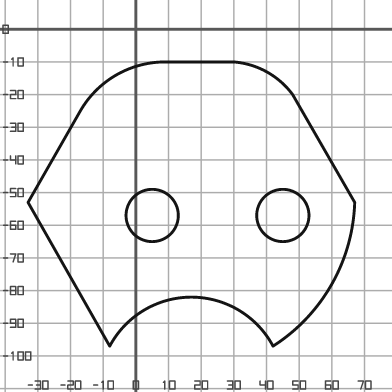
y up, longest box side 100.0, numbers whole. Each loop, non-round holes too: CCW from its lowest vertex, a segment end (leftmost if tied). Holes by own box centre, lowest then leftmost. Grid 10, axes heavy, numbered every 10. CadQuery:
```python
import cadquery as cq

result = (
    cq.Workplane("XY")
    .moveTo(-8.0, -97.0)
    .threePointArc((17.0, -82.0), (42.0, -97.0))
    .threePointArc((60.0, -78.0), (67.0, -53.0))
    .lineTo(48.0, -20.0)
    .threePointArc((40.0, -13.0), (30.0, -10.0))
    .lineTo(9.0, -10.0)
    .threePointArc((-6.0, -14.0), (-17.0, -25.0))
    .lineTo(-33.0, -53.0)
    .close()
    .moveTo(5.0, -57.0)
    .circle(8.0)
    .moveTo(45.0, -57.0)
    .circle(8.0)
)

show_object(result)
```